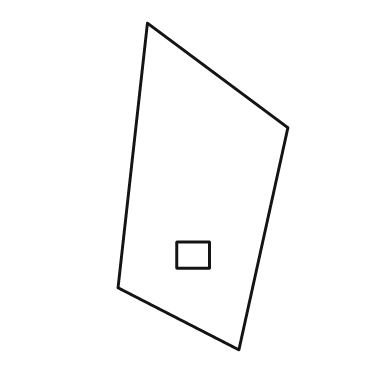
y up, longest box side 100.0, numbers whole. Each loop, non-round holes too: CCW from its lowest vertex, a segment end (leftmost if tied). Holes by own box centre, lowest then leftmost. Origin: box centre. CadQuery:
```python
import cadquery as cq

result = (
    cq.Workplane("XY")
    .moveTo(11.0, -50.0)
    .lineTo(26.0, 18.0)
    .lineTo(-17.0, 50.0)
    .lineTo(-26.0, -31.0)
    .close()
    .moveTo(-8.0, -25.0)
    .lineTo(2.0, -25.0)
    .lineTo(2.0, -17.0)
    .lineTo(-8.0, -17.0)
    .close()
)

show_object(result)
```